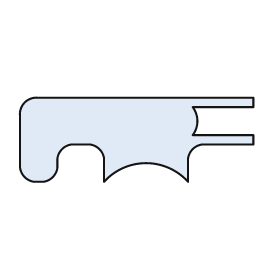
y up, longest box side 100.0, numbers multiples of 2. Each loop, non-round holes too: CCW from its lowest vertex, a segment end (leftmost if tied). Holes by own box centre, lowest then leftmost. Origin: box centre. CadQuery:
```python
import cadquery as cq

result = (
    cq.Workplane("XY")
    .moveTo(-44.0, -18.0)
    .lineTo(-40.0, -18.0)
    .threePointArc((-36.0, -16.0), (-34.0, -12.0))
    .lineTo(-34.0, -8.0)
    .threePointArc((-32.0, -4.0), (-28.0, -2.0))
    .lineTo(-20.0, -2.0)
    .threePointArc((-16.0, -4.0), (-14.0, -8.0))
    .lineTo(-14.0, -18.0)
    .threePointArc((4.0, -10.0), (22.0, -18.0))
    .lineTo(22.0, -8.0)
    .threePointArc((24.0, -4.0), (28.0, -2.0))
    .lineTo(50.0, -2.0)
    .lineTo(50.0, 2.0)
    .lineTo(24.0, 2.0)
    .threePointArc((26.0, 8.0), (24.0, 14.0))
    .lineTo(50.0, 14.0)
    .lineTo(50.0, 18.0)
    .lineTo(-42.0, 18.0)
    .threePointArc((-48.0, 16.0), (-50.0, 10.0))
    .lineTo(-50.0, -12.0)
    .threePointArc((-48.0, -16.0), (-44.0, -18.0))
    .close()
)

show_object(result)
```